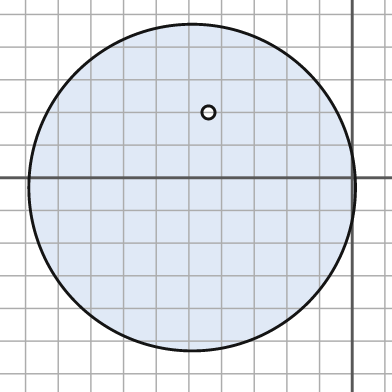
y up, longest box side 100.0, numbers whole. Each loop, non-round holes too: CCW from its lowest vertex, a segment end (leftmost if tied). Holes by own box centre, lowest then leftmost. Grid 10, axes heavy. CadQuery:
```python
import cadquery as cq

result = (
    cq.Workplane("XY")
    .moveTo(-49.0, -3.0)
    .circle(50.0)
    .moveTo(-44.0, 20.0)
    .circle(2.0)
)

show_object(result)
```